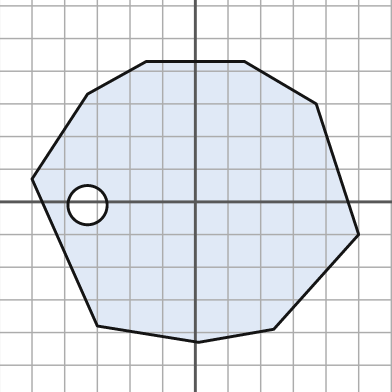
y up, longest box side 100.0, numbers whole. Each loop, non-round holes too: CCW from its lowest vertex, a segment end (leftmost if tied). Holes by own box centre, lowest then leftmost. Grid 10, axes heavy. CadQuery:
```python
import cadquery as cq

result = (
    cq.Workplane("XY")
    .moveTo(1.0, -43.0)
    .lineTo(24.0, -39.0)
    .lineTo(50.0, -10.0)
    .lineTo(37.0, 30.0)
    .lineTo(15.0, 43.0)
    .lineTo(-15.0, 43.0)
    .lineTo(-33.0, 33.0)
    .lineTo(-50.0, 7.0)
    .lineTo(-30.0, -38.0)
    .close()
    .moveTo(-33.0, -1.0)
    .circle(6.0)
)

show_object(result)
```